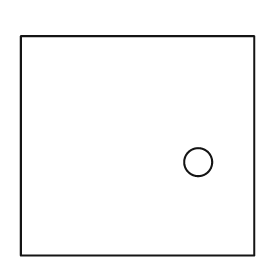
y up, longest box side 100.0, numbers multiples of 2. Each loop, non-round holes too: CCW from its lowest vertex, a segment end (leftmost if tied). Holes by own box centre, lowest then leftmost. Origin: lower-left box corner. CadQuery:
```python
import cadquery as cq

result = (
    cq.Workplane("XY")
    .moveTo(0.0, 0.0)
    .lineTo(100.0, 0.0)
    .lineTo(100.0, 94.0)
    .lineTo(0.0, 94.0)
    .close()
    .moveTo(76.0, 40.0)
    .circle(6.0)
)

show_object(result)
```